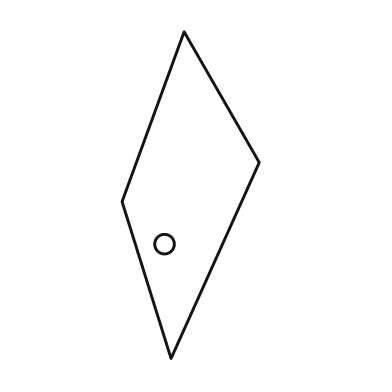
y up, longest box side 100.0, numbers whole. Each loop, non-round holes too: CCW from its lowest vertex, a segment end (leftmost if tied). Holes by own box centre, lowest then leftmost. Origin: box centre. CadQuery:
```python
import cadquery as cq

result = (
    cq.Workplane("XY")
    .moveTo(-6.0, -50.0)
    .lineTo(21.0, 10.0)
    .lineTo(-2.0, 50.0)
    .lineTo(-21.0, -2.0)
    .close()
    .moveTo(-8.0, -15.0)
    .circle(3.0)
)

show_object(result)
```